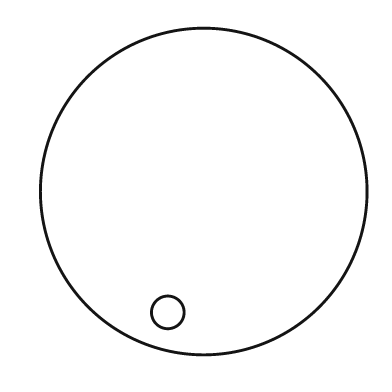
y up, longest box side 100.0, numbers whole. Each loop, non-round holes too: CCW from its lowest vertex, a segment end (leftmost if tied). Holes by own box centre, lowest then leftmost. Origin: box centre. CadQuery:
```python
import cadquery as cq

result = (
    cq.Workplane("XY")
    .moveTo(0.0, 0.0)
    .circle(50.0)
    .moveTo(-11.0, -37.0)
    .circle(5.0)
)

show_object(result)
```